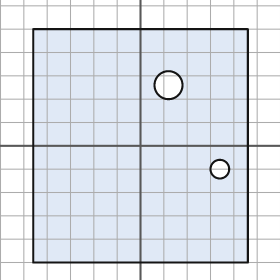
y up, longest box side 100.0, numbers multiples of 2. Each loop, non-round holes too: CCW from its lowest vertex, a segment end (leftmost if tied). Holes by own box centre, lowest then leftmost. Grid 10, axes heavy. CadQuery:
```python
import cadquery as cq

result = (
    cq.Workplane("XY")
    .moveTo(-46.0, -50.0)
    .lineTo(46.0, -50.0)
    .lineTo(46.0, 50.0)
    .lineTo(-46.0, 50.0)
    .close()
    .moveTo(34.0, -10.0)
    .circle(4.0)
    .moveTo(12.0, 26.0)
    .circle(6.0)
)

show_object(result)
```